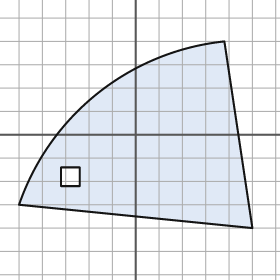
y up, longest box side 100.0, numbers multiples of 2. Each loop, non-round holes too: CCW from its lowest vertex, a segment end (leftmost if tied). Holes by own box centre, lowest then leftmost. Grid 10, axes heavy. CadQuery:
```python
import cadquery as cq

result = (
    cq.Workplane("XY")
    .moveTo(50.0, -40.0)
    .lineTo(38.0, 40.0)
    .threePointArc((-16.0, 18.0), (-50.0, -30.0))
    .close()
    .moveTo(-32.0, -22.0)
    .lineTo(-24.0, -22.0)
    .lineTo(-24.0, -14.0)
    .lineTo(-32.0, -14.0)
    .close()
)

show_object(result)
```